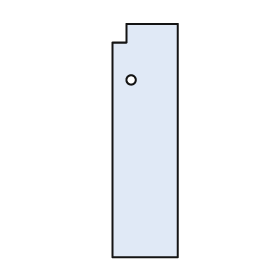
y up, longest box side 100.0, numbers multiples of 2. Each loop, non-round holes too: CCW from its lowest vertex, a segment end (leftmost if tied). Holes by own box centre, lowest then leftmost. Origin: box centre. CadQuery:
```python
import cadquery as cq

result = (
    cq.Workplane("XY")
    .moveTo(-14.0, -50.0)
    .lineTo(14.0, -50.0)
    .lineTo(14.0, 50.0)
    .lineTo(-8.0, 50.0)
    .lineTo(-8.0, 42.0)
    .lineTo(-14.0, 42.0)
    .close()
    .moveTo(-6.0, 26.0)
    .circle(2.0)
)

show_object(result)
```